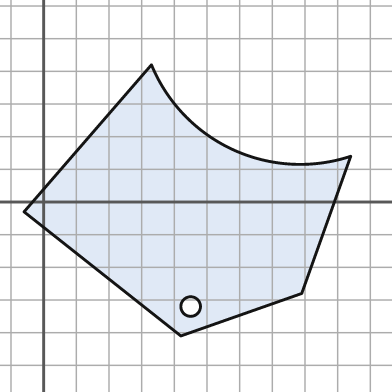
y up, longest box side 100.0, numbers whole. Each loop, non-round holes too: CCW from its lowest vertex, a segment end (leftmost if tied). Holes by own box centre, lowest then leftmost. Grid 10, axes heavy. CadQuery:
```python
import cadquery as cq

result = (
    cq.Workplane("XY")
    .moveTo(42.0, -41.0)
    .lineTo(79.0, -28.0)
    .lineTo(94.0, 14.0)
    .threePointArc((58.0, 16.0), (33.0, 42.0))
    .lineTo(-6.0, -3.0)
    .close()
    .moveTo(45.0, -32.0)
    .circle(3.0)
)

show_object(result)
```